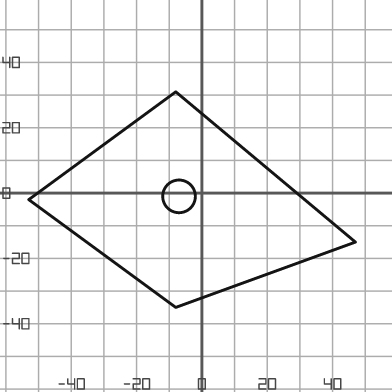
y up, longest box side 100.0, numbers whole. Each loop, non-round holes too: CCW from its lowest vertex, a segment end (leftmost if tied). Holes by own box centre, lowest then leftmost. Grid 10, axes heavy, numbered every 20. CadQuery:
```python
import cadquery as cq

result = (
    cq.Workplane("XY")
    .moveTo(-8.0, -35.0)
    .lineTo(47.0, -15.0)
    .lineTo(-8.0, 31.0)
    .lineTo(-53.0, -2.0)
    .close()
    .moveTo(-7.0, -1.0)
    .circle(5.0)
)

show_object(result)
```